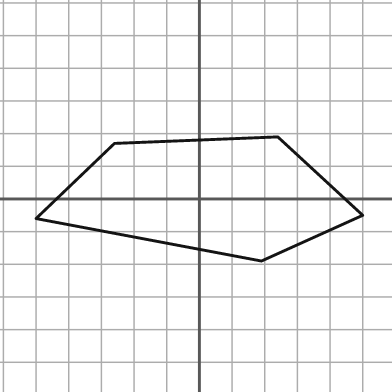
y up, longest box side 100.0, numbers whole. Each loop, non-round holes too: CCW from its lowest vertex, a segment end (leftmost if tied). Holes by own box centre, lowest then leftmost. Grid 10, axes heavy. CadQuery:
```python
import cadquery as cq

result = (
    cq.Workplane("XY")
    .moveTo(19.0, -19.0)
    .lineTo(50.0, -5.0)
    .lineTo(24.0, 19.0)
    .lineTo(-26.0, 17.0)
    .lineTo(-50.0, -6.0)
    .close()
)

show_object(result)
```